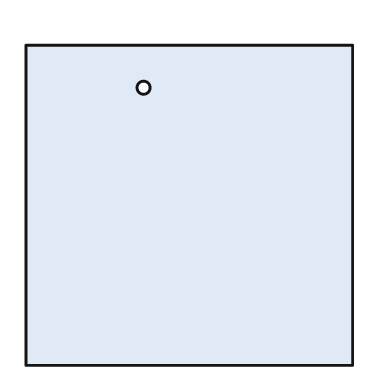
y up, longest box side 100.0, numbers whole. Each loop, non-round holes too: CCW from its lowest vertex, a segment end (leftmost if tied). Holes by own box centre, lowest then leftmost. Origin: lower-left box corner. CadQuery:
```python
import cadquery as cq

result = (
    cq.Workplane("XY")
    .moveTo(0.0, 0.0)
    .lineTo(100.0, 0.0)
    .lineTo(100.0, 98.0)
    .lineTo(0.0, 98.0)
    .close()
    .moveTo(36.0, 85.0)
    .circle(2.0)
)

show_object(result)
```